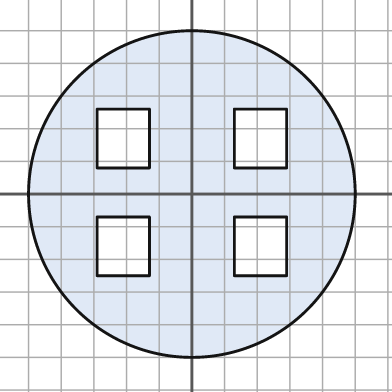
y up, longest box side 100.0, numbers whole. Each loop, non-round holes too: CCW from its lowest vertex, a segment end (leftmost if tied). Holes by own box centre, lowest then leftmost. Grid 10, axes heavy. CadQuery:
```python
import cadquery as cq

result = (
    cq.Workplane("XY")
    .moveTo(0.0, 0.0)
    .circle(50.0)
    .moveTo(-29.0, -25.0)
    .lineTo(-13.0, -25.0)
    .lineTo(-13.0, -7.0)
    .lineTo(-29.0, -7.0)
    .close()
    .moveTo(13.0, -25.0)
    .lineTo(29.0, -25.0)
    .lineTo(29.0, -7.0)
    .lineTo(13.0, -7.0)
    .close()
    .moveTo(-29.0, 8.0)
    .lineTo(-13.0, 8.0)
    .lineTo(-13.0, 26.0)
    .lineTo(-29.0, 26.0)
    .close()
    .moveTo(13.0, 8.0)
    .lineTo(29.0, 8.0)
    .lineTo(29.0, 26.0)
    .lineTo(13.0, 26.0)
    .close()
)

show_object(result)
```